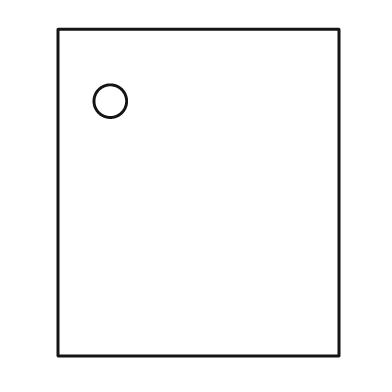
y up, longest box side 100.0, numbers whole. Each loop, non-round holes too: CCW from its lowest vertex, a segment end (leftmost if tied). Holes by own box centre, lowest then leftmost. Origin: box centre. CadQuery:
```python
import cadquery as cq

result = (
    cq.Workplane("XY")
    .moveTo(-43.0, -50.0)
    .lineTo(43.0, -50.0)
    .lineTo(43.0, 50.0)
    .lineTo(-43.0, 50.0)
    .close()
    .moveTo(-27.0, 28.0)
    .circle(5.0)
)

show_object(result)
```